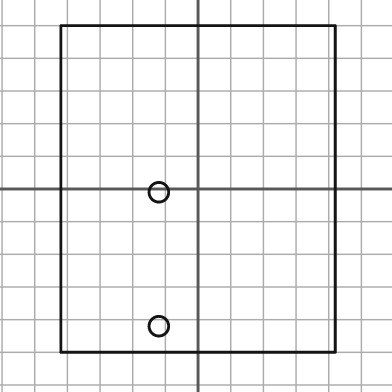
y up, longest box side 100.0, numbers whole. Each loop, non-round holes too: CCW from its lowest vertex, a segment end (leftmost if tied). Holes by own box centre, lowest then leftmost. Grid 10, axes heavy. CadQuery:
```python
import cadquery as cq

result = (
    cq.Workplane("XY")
    .moveTo(-42.0, -50.0)
    .lineTo(42.0, -50.0)
    .lineTo(42.0, 50.0)
    .lineTo(-42.0, 50.0)
    .close()
    .moveTo(-12.0, -42.0)
    .circle(3.0)
    .moveTo(-12.0, -1.0)
    .circle(3.0)
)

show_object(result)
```